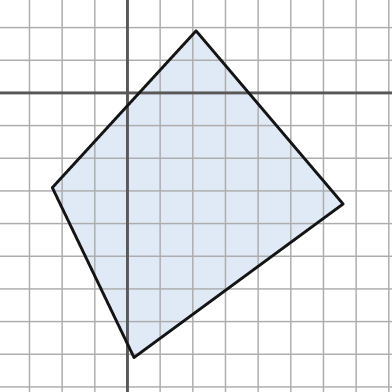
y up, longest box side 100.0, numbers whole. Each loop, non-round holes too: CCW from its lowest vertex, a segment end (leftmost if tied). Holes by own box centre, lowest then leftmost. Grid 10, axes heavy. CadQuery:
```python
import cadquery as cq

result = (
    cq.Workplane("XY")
    .moveTo(2.0, -81.0)
    .lineTo(66.0, -34.0)
    .lineTo(21.0, 19.0)
    .lineTo(-23.0, -29.0)
    .close()
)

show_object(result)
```